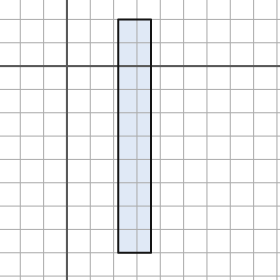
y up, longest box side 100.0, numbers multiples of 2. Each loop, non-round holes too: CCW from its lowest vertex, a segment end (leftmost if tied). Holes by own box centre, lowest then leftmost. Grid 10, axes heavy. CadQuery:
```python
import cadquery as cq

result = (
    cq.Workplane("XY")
    .moveTo(22.0, -80.0)
    .lineTo(36.0, -80.0)
    .lineTo(36.0, 20.0)
    .lineTo(22.0, 20.0)
    .close()
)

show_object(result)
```